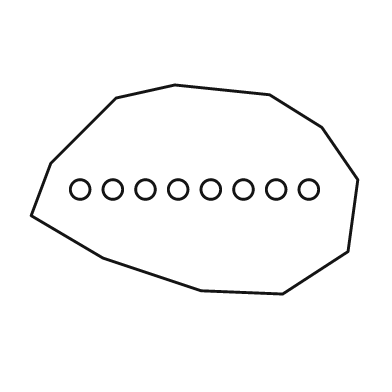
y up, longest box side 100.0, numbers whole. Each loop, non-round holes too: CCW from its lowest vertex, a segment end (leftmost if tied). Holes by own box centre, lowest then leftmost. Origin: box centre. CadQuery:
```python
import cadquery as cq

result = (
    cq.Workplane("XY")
    .moveTo(27.0, -32.0)
    .lineTo(47.0, -19.0)
    .lineTo(50.0, 3.0)
    .lineTo(39.0, 19.0)
    .lineTo(23.0, 29.0)
    .lineTo(-6.0, 32.0)
    .lineTo(-24.0, 28.0)
    .lineTo(-44.0, 8.0)
    .lineTo(-50.0, -8.0)
    .lineTo(-28.0, -21.0)
    .lineTo(2.0, -31.0)
    .close()
    .moveTo(-35.0, 0.0)
    .circle(3.0)
    .moveTo(-25.0, 0.0)
    .circle(3.0)
    .moveTo(-15.0, 0.0)
    .circle(3.0)
    .moveTo(-5.0, 0.0)
    .circle(3.0)
    .moveTo(5.0, 0.0)
    .circle(3.0)
    .moveTo(15.0, 0.0)
    .circle(3.0)
    .moveTo(25.0, 0.0)
    .circle(3.0)
    .moveTo(35.0, 0.0)
    .circle(3.0)
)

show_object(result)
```